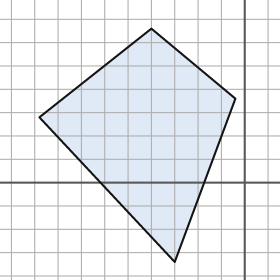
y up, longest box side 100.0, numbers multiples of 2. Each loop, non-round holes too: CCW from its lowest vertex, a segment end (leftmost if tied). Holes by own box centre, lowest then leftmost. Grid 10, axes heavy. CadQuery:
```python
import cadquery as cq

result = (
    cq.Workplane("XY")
    .moveTo(-30.0, -34.0)
    .lineTo(-4.0, 36.0)
    .lineTo(-40.0, 66.0)
    .lineTo(-88.0, 28.0)
    .close()
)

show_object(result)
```